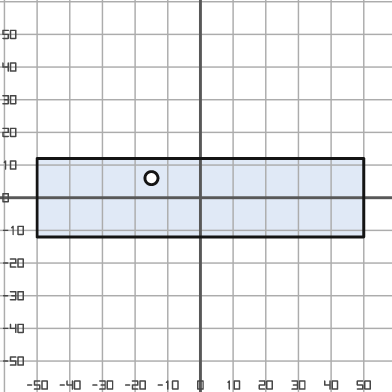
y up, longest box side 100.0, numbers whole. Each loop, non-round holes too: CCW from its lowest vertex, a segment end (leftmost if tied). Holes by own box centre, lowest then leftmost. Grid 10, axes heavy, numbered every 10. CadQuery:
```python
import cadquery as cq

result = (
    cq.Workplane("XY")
    .moveTo(-50.0, -12.0)
    .lineTo(50.0, -12.0)
    .lineTo(50.0, 12.0)
    .lineTo(-50.0, 12.0)
    .close()
    .moveTo(-15.0, 6.0)
    .circle(2.0)
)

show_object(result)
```